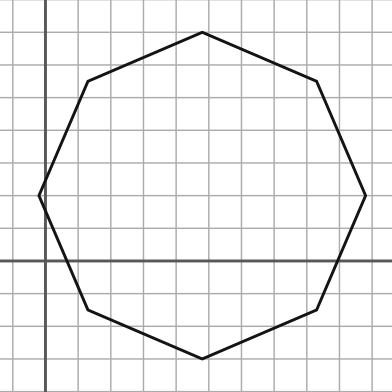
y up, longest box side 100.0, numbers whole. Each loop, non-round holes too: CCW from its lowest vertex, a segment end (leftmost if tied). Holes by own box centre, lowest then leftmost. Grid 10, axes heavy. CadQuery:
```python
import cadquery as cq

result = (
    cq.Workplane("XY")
    .moveTo(48.0, -30.0)
    .lineTo(83.0, -15.0)
    .lineTo(98.0, 20.0)
    .lineTo(83.0, 55.0)
    .lineTo(48.0, 70.0)
    .lineTo(13.0, 55.0)
    .lineTo(-2.0, 20.0)
    .lineTo(13.0, -15.0)
    .close()
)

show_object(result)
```